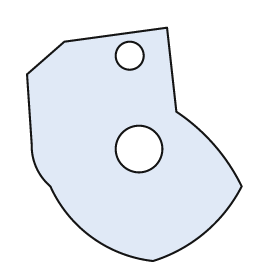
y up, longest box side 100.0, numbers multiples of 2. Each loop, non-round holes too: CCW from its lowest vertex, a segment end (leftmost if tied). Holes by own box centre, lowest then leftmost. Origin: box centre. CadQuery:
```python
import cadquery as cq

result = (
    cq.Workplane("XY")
    .moveTo(8.0, -50.0)
    .threePointArc((30.0, -38.0), (46.0, -18.0))
    .threePointArc((34.0, 0.0), (18.0, 14.0))
    .lineTo(14.0, 50.0)
    .lineTo(-30.0, 44.0)
    .lineTo(-46.0, 30.0)
    .lineTo(-44.0, 0.0)
    .threePointArc((-42.0, -10.0), (-36.0, -18.0))
    .threePointArc((-18.0, -40.0), (8.0, -50.0))
    .close()
    .moveTo(2.0, -2.0)
    .circle(10.0)
    .moveTo(-2.0, 38.0)
    .circle(6.0)
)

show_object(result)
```